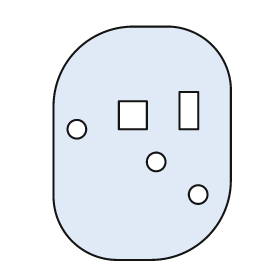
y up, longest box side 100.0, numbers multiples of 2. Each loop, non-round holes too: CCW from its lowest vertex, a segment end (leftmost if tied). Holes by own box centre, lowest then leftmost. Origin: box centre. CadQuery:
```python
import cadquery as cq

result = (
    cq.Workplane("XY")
    .moveTo(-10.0, -50.0)
    .lineTo(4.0, -50.0)
    .threePointArc((28.0, -40.0), (38.0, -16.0))
    .lineTo(38.0, 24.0)
    .threePointArc((30.0, 42.0), (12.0, 50.0))
    .lineTo(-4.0, 50.0)
    .threePointArc((-28.0, 40.0), (-38.0, 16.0))
    .lineTo(-38.0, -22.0)
    .threePointArc((-30.0, -42.0), (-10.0, -50.0))
    .close()
    .moveTo(24.0, -22.0)
    .circle(4.0)
    .moveTo(6.0, -8.0)
    .circle(4.0)
    .moveTo(-28.0, 6.0)
    .circle(4.0)
    .moveTo(-10.0, 6.0)
    .lineTo(2.0, 6.0)
    .lineTo(2.0, 18.0)
    .lineTo(-10.0, 18.0)
    .close()
    .moveTo(16.0, 6.0)
    .lineTo(24.0, 6.0)
    .lineTo(24.0, 22.0)
    .lineTo(16.0, 22.0)
    .close()
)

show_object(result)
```